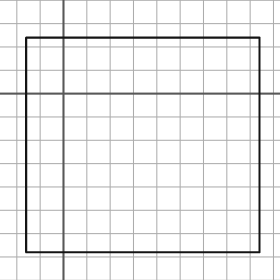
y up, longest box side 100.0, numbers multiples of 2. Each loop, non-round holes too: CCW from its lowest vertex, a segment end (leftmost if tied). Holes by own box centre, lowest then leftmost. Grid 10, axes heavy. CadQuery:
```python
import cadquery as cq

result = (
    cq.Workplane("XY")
    .moveTo(-16.0, -68.0)
    .lineTo(84.0, -68.0)
    .lineTo(84.0, 24.0)
    .lineTo(-16.0, 24.0)
    .close()
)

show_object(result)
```